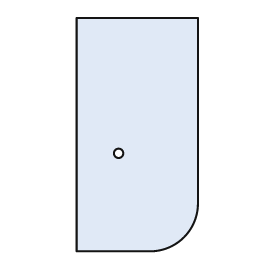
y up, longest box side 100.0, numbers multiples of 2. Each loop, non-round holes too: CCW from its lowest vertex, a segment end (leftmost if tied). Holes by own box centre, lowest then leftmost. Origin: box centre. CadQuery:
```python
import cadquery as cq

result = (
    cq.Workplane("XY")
    .moveTo(-26.0, -50.0)
    .lineTo(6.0, -50.0)
    .threePointArc((20.0, -44.0), (26.0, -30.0))
    .lineTo(26.0, 50.0)
    .lineTo(-26.0, 50.0)
    .close()
    .moveTo(-8.0, -8.0)
    .circle(2.0)
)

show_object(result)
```